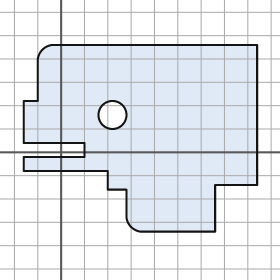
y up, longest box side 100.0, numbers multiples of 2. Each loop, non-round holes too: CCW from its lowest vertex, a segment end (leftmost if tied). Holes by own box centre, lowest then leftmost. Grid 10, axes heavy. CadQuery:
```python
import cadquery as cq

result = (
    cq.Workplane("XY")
    .moveTo(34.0, -34.0)
    .lineTo(66.0, -34.0)
    .lineTo(66.0, -14.0)
    .lineTo(84.0, -14.0)
    .lineTo(84.0, 46.0)
    .lineTo(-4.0, 46.0)
    .threePointArc((-8.0, 44.0), (-10.0, 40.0))
    .lineTo(-10.0, 22.0)
    .lineTo(-16.0, 22.0)
    .lineTo(-16.0, 4.0)
    .lineTo(10.0, 4.0)
    .lineTo(10.0, -2.0)
    .lineTo(-16.0, -2.0)
    .lineTo(-16.0, -8.0)
    .lineTo(20.0, -8.0)
    .lineTo(20.0, -16.0)
    .lineTo(28.0, -16.0)
    .lineTo(28.0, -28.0)
    .threePointArc((30.0, -32.0), (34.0, -34.0))
    .close()
    .moveTo(22.0, 16.0)
    .circle(6.0)
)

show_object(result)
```